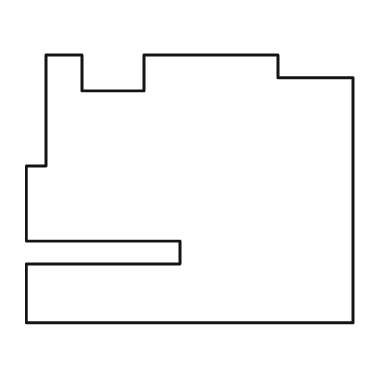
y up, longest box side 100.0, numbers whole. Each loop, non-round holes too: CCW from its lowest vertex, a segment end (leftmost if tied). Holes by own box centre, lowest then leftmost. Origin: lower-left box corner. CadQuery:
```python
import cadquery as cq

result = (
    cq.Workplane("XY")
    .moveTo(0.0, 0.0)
    .lineTo(100.0, 0.0)
    .lineTo(100.0, 75.0)
    .lineTo(77.0, 75.0)
    .lineTo(77.0, 82.0)
    .lineTo(36.0, 82.0)
    .lineTo(36.0, 71.0)
    .lineTo(17.0, 71.0)
    .lineTo(17.0, 82.0)
    .lineTo(6.0, 82.0)
    .lineTo(6.0, 48.0)
    .lineTo(0.0, 48.0)
    .lineTo(0.0, 25.0)
    .lineTo(47.0, 25.0)
    .lineTo(47.0, 18.0)
    .lineTo(0.0, 18.0)
    .close()
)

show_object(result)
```